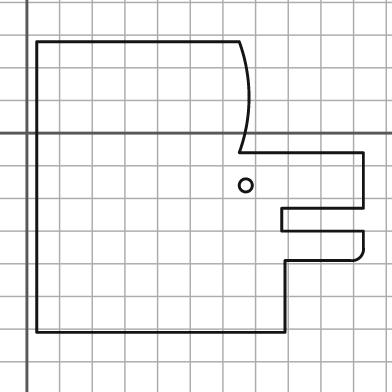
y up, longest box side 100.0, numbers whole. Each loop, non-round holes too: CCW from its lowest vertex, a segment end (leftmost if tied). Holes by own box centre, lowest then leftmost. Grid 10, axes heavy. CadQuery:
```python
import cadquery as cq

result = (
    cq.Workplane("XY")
    .moveTo(3.0, -61.0)
    .lineTo(79.0, -61.0)
    .lineTo(79.0, -39.0)
    .lineTo(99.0, -39.0)
    .threePointArc((102.0, -38.0), (103.0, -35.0))
    .lineTo(103.0, -30.0)
    .lineTo(78.0, -30.0)
    .lineTo(78.0, -23.0)
    .lineTo(103.0, -23.0)
    .lineTo(103.0, -6.0)
    .lineTo(65.0, -6.0)
    .threePointArc((68.0, 11.0), (65.0, 28.0))
    .lineTo(3.0, 28.0)
    .close()
    .moveTo(67.0, -16.0)
    .circle(2.0)
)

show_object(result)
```